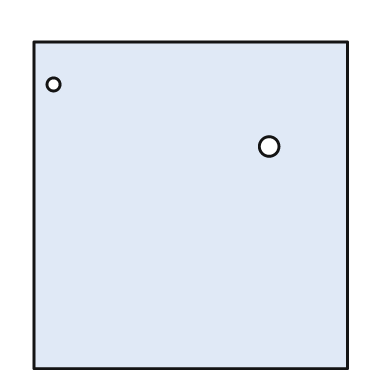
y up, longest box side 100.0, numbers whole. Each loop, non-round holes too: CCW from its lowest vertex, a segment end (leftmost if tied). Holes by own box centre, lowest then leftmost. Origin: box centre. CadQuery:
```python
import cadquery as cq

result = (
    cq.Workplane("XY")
    .moveTo(-48.0, -50.0)
    .lineTo(48.0, -50.0)
    .lineTo(48.0, 50.0)
    .lineTo(-48.0, 50.0)
    .close()
    .moveTo(24.0, 18.0)
    .circle(3.0)
    .moveTo(-42.0, 37.0)
    .circle(2.0)
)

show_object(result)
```